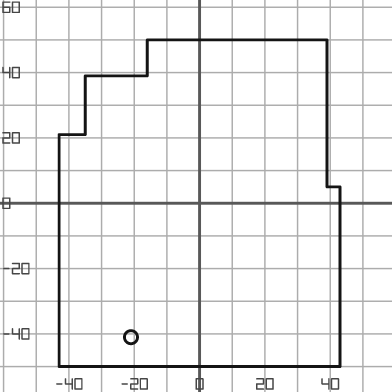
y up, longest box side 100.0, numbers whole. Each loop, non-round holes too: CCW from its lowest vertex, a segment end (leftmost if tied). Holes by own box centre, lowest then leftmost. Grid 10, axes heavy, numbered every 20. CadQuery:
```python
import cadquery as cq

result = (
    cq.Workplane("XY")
    .moveTo(-43.0, -50.0)
    .lineTo(43.0, -50.0)
    .lineTo(43.0, 5.0)
    .lineTo(39.0, 5.0)
    .lineTo(39.0, 50.0)
    .lineTo(-16.0, 50.0)
    .lineTo(-16.0, 39.0)
    .lineTo(-35.0, 39.0)
    .lineTo(-35.0, 21.0)
    .lineTo(-43.0, 21.0)
    .close()
    .moveTo(-21.0, -41.0)
    .circle(2.0)
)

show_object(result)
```